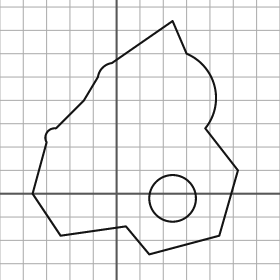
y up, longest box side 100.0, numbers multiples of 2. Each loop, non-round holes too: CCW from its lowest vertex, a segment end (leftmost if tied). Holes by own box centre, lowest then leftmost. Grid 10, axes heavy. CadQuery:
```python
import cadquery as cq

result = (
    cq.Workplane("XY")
    .moveTo(14.0, -26.0)
    .lineTo(44.0, -18.0)
    .lineTo(52.0, 10.0)
    .lineTo(38.0, 28.0)
    .threePointArc((42.0, 46.0), (30.0, 60.0))
    .lineTo(24.0, 74.0)
    .lineTo(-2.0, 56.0)
    .threePointArc((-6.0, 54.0), (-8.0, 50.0))
    .lineTo(-14.0, 40.0)
    .lineTo(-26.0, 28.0)
    .threePointArc((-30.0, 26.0), (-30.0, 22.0))
    .lineTo(-36.0, 0.0)
    .lineTo(-24.0, -18.0)
    .lineTo(4.0, -14.0)
    .close()
    .moveTo(24.0, -2.0)
    .circle(10.0)
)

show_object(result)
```